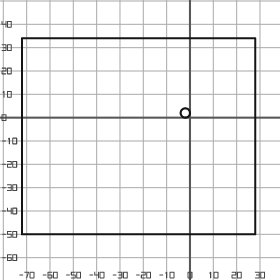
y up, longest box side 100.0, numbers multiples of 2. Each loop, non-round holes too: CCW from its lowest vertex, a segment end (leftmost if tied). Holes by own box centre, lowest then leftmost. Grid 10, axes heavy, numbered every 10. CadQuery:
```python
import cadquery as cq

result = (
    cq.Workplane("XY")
    .moveTo(-72.0, -50.0)
    .lineTo(28.0, -50.0)
    .lineTo(28.0, 34.0)
    .lineTo(-72.0, 34.0)
    .close()
    .moveTo(-2.0, 2.0)
    .circle(2.0)
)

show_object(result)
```